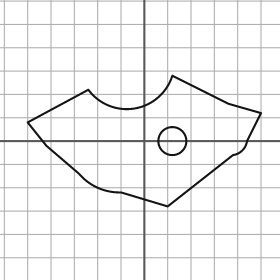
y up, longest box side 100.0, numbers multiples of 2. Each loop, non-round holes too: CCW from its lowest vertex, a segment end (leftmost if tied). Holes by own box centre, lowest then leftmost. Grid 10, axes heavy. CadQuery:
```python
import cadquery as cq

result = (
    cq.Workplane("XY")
    .moveTo(10.0, -28.0)
    .lineTo(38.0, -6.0)
    .threePointArc((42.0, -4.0), (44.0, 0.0))
    .lineTo(50.0, 12.0)
    .lineTo(36.0, 16.0)
    .lineTo(12.0, 28.0)
    .threePointArc((-4.0, 14.0), (-24.0, 22.0))
    .lineTo(-50.0, 8.0)
    .lineTo(-42.0, -2.0)
    .lineTo(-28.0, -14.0)
    .threePointArc((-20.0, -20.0), (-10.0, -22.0))
    .close()
    .moveTo(12.0, 0.0)
    .circle(6.0)
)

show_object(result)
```